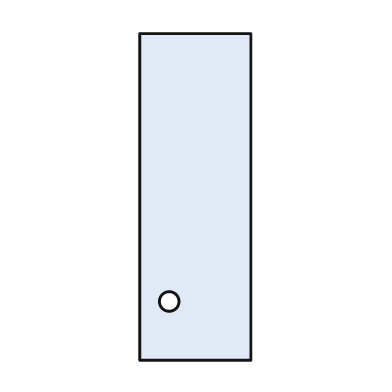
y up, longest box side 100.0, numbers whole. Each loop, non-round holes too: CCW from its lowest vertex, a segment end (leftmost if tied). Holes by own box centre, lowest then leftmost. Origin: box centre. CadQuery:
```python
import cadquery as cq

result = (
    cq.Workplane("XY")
    .moveTo(-17.0, -50.0)
    .lineTo(17.0, -50.0)
    .lineTo(17.0, 50.0)
    .lineTo(-17.0, 50.0)
    .close()
    .moveTo(-8.0, -32.0)
    .circle(3.0)
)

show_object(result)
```